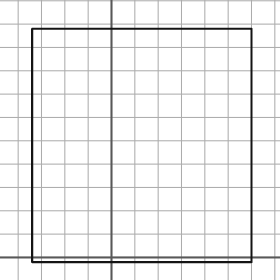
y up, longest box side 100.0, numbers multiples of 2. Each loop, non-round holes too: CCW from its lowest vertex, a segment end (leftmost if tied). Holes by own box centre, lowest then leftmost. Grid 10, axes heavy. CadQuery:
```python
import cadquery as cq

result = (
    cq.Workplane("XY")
    .moveTo(-34.0, -2.0)
    .lineTo(60.0, -2.0)
    .lineTo(60.0, 98.0)
    .lineTo(-34.0, 98.0)
    .close()
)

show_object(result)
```